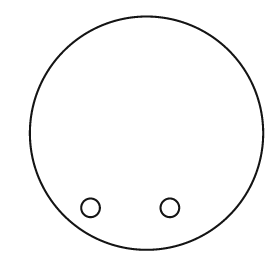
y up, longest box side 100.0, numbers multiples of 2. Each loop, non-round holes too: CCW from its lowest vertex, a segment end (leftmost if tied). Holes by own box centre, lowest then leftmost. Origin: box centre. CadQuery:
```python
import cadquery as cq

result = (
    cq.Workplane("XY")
    .moveTo(0.0, 0.0)
    .circle(50.0)
    .moveTo(-24.0, -32.0)
    .circle(4.0)
    .moveTo(10.0, -32.0)
    .circle(4.0)
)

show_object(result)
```